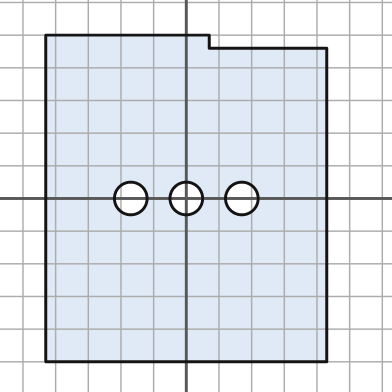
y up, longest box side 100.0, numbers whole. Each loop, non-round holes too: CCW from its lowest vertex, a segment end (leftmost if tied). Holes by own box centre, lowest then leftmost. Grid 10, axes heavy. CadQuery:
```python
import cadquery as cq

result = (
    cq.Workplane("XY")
    .moveTo(-43.0, -50.0)
    .lineTo(43.0, -50.0)
    .lineTo(43.0, 46.0)
    .lineTo(7.0, 46.0)
    .lineTo(7.0, 50.0)
    .lineTo(-43.0, 50.0)
    .close()
    .moveTo(-17.0, 0.0)
    .circle(5.0)
    .moveTo(0.0, 0.0)
    .circle(5.0)
    .moveTo(17.0, 0.0)
    .circle(5.0)
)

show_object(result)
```